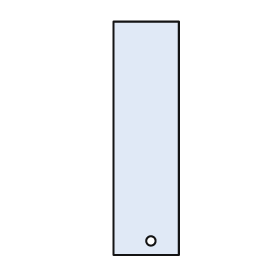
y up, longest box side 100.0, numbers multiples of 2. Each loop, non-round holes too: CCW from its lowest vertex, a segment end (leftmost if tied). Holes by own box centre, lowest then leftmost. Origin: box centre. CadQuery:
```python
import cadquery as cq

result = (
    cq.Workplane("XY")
    .moveTo(-14.0, -50.0)
    .lineTo(14.0, -50.0)
    .lineTo(14.0, 50.0)
    .lineTo(-14.0, 50.0)
    .close()
    .moveTo(2.0, -44.0)
    .circle(2.0)
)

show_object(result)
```